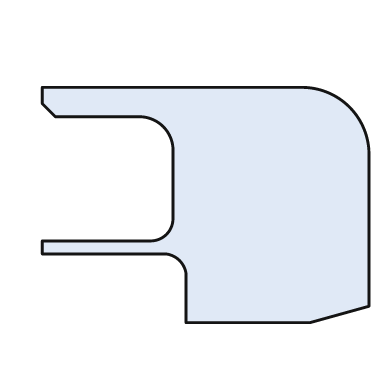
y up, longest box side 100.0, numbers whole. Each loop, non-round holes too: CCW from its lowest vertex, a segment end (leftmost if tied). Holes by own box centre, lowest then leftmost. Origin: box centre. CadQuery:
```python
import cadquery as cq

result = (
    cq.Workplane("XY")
    .moveTo(-6.0, -36.0)
    .lineTo(32.0, -36.0)
    .lineTo(50.0, -31.0)
    .lineTo(50.0, 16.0)
    .threePointArc((44.0, 30.0), (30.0, 36.0))
    .lineTo(-50.0, 36.0)
    .lineTo(-50.0, 31.0)
    .lineTo(-46.0, 27.0)
    .lineTo(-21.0, 27.0)
    .threePointArc((-13.0, 24.0), (-10.0, 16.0))
    .lineTo(-10.0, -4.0)
    .threePointArc((-12.0, -9.0), (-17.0, -11.0))
    .lineTo(-50.0, -11.0)
    .lineTo(-50.0, -15.0)
    .lineTo(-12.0, -15.0)
    .threePointArc((-8.0, -17.0), (-6.0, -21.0))
    .close()
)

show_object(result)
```